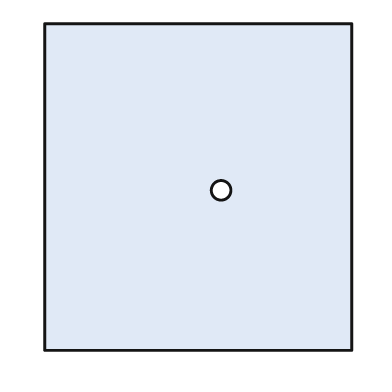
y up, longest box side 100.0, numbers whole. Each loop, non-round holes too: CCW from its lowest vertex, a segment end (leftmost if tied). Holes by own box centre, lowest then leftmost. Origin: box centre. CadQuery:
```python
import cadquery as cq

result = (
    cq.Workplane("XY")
    .moveTo(-47.0, -50.0)
    .lineTo(47.0, -50.0)
    .lineTo(47.0, 50.0)
    .lineTo(-47.0, 50.0)
    .close()
    .moveTo(7.0, -1.0)
    .circle(3.0)
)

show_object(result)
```